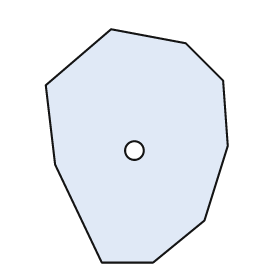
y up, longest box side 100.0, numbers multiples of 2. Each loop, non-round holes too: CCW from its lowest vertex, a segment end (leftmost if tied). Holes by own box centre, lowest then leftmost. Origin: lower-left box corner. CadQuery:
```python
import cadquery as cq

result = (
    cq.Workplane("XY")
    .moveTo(24.0, 0.0)
    .lineTo(46.0, 0.0)
    .lineTo(68.0, 18.0)
    .lineTo(78.0, 50.0)
    .lineTo(76.0, 78.0)
    .lineTo(60.0, 94.0)
    .lineTo(28.0, 100.0)
    .lineTo(0.0, 76.0)
    .lineTo(4.0, 42.0)
    .close()
    .moveTo(38.0, 48.0)
    .circle(4.0)
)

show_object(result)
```